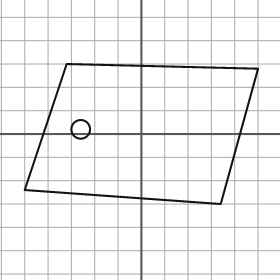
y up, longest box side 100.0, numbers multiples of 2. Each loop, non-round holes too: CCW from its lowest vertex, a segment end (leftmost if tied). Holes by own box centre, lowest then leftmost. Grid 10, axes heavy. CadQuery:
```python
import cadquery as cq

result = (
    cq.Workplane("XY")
    .moveTo(34.0, -30.0)
    .lineTo(50.0, 28.0)
    .lineTo(-32.0, 30.0)
    .lineTo(-50.0, -24.0)
    .close()
    .moveTo(-26.0, 2.0)
    .circle(4.0)
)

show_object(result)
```